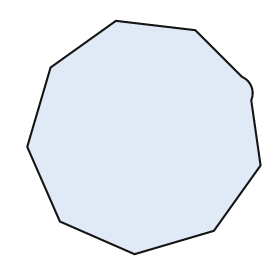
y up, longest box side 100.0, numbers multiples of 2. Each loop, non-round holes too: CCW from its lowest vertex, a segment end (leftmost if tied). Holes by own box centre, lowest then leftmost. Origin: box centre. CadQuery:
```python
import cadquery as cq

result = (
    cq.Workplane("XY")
    .moveTo(-4.0, -50.0)
    .lineTo(30.0, -40.0)
    .lineTo(50.0, -12.0)
    .lineTo(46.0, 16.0)
    .threePointArc((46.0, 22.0), (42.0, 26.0))
    .lineTo(22.0, 46.0)
    .lineTo(-12.0, 50.0)
    .lineTo(-40.0, 30.0)
    .lineTo(-50.0, -4.0)
    .lineTo(-36.0, -36.0)
    .close()
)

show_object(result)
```